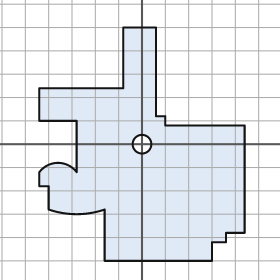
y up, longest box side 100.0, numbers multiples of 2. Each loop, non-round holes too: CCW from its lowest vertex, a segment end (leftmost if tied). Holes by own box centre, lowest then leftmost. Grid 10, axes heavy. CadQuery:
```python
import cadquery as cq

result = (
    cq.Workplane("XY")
    .moveTo(-16.0, -50.0)
    .lineTo(30.0, -50.0)
    .lineTo(30.0, -42.0)
    .lineTo(36.0, -42.0)
    .lineTo(36.0, -38.0)
    .lineTo(44.0, -38.0)
    .lineTo(44.0, 8.0)
    .lineTo(10.0, 8.0)
    .lineTo(10.0, 12.0)
    .lineTo(6.0, 12.0)
    .lineTo(6.0, 50.0)
    .lineTo(-8.0, 50.0)
    .lineTo(-8.0, 24.0)
    .lineTo(-44.0, 24.0)
    .lineTo(-44.0, 10.0)
    .lineTo(-28.0, 10.0)
    .lineTo(-28.0, -12.0)
    .threePointArc((-36.0, -8.0), (-44.0, -12.0))
    .lineTo(-44.0, -18.0)
    .lineTo(-40.0, -18.0)
    .lineTo(-40.0, -28.0)
    .threePointArc((-28.0, -30.0), (-16.0, -28.0))
    .close()
    .moveTo(0.0, 0.0)
    .circle(4.0)
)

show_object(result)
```